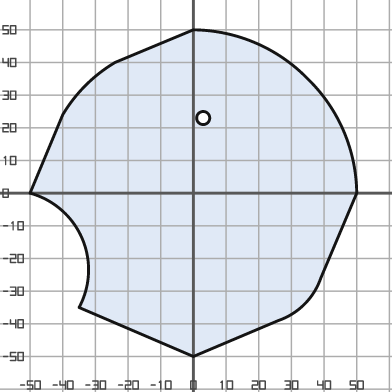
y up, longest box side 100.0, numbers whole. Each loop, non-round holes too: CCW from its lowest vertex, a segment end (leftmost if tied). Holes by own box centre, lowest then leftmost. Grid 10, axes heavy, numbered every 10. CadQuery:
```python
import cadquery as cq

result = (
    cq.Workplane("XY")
    .moveTo(0.0, -50.0)
    .lineTo(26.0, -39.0)
    .threePointArc((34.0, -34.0), (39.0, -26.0))
    .lineTo(50.0, 0.0)
    .threePointArc((46.0, 19.0), (35.0, 35.0))
    .threePointArc((19.0, 46.0), (0.0, 50.0))
    .lineTo(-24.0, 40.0)
    .threePointArc((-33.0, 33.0), (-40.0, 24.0))
    .lineTo(-50.0, 0.0)
    .threePointArc((-34.0, -14.0), (-35.0, -35.0))
    .close()
    .moveTo(3.0, 23.0)
    .circle(2.0)
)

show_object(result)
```